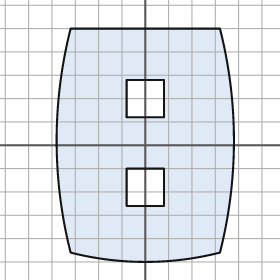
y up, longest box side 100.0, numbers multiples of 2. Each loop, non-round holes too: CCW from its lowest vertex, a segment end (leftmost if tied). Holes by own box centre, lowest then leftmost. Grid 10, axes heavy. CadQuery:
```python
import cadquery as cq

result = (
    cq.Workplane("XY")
    .moveTo(-32.0, -46.0)
    .threePointArc((0.0, -50.0), (32.0, -46.0))
    .threePointArc((38.0, 2.0), (32.0, 50.0))
    .lineTo(-32.0, 50.0)
    .threePointArc((-38.0, 2.0), (-32.0, -46.0))
    .close()
    .moveTo(-8.0, -26.0)
    .lineTo(8.0, -26.0)
    .lineTo(8.0, -10.0)
    .lineTo(-8.0, -10.0)
    .close()
    .moveTo(-8.0, 12.0)
    .lineTo(8.0, 12.0)
    .lineTo(8.0, 28.0)
    .lineTo(-8.0, 28.0)
    .close()
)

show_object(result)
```